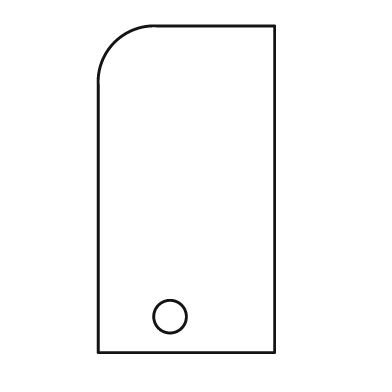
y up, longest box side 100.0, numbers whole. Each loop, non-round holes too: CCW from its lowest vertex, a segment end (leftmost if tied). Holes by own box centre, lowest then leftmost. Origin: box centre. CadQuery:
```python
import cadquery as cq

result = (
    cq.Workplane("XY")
    .moveTo(-27.0, -50.0)
    .lineTo(27.0, -50.0)
    .lineTo(27.0, 50.0)
    .lineTo(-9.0, 50.0)
    .threePointArc((-22.0, 45.0), (-27.0, 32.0))
    .close()
    .moveTo(-5.0, -39.0)
    .circle(5.0)
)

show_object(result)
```